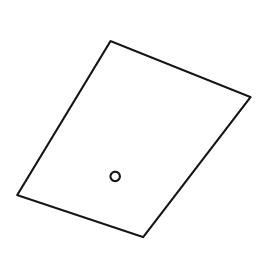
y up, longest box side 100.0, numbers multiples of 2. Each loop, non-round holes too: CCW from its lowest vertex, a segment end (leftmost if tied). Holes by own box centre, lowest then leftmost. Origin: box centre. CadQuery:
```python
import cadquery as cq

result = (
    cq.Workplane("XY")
    .moveTo(4.0, -42.0)
    .lineTo(50.0, 18.0)
    .lineTo(-10.0, 42.0)
    .lineTo(-50.0, -24.0)
    .close()
    .moveTo(-8.0, -16.0)
    .circle(2.0)
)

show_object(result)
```